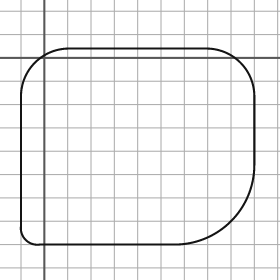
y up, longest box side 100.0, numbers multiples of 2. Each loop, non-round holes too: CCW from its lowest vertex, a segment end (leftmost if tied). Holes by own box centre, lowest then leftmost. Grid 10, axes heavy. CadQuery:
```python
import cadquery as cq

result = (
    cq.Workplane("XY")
    .moveTo(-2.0, -80.0)
    .lineTo(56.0, -80.0)
    .threePointArc((80.0, -70.0), (90.0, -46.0))
    .lineTo(90.0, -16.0)
    .threePointArc((84.0, -2.0), (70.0, 4.0))
    .lineTo(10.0, 4.0)
    .threePointArc((-4.0, -2.0), (-10.0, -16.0))
    .lineTo(-10.0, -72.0)
    .threePointArc((-8.0, -78.0), (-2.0, -80.0))
    .close()
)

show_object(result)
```